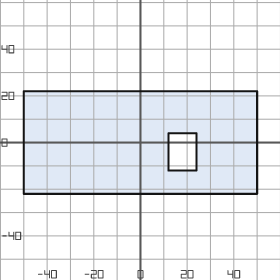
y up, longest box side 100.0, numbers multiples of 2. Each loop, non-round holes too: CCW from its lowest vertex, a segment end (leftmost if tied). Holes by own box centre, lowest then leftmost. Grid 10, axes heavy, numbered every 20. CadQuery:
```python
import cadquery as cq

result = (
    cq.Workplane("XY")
    .moveTo(-50.0, -22.0)
    .lineTo(50.0, -22.0)
    .lineTo(50.0, 22.0)
    .lineTo(-50.0, 22.0)
    .close()
    .moveTo(12.0, -12.0)
    .lineTo(24.0, -12.0)
    .lineTo(24.0, 4.0)
    .lineTo(12.0, 4.0)
    .close()
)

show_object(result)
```